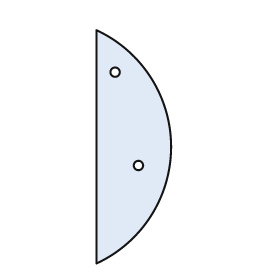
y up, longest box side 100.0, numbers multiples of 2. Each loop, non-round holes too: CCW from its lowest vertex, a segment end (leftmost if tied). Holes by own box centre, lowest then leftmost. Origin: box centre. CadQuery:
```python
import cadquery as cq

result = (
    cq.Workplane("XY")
    .moveTo(-16.0, -50.0)
    .threePointArc((16.0, 0.0), (-16.0, 50.0))
    .close()
    .moveTo(2.0, -8.0)
    .circle(2.0)
    .moveTo(-8.0, 32.0)
    .circle(2.0)
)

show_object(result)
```